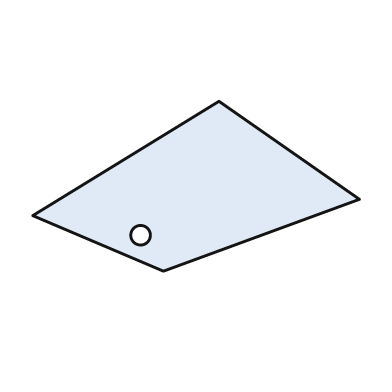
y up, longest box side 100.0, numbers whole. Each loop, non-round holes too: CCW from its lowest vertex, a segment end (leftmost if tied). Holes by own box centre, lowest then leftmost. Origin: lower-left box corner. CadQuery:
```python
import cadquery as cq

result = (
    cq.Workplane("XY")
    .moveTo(40.0, 0.0)
    .lineTo(100.0, 22.0)
    .lineTo(57.0, 52.0)
    .lineTo(0.0, 17.0)
    .close()
    .moveTo(33.0, 11.0)
    .circle(3.0)
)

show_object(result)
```